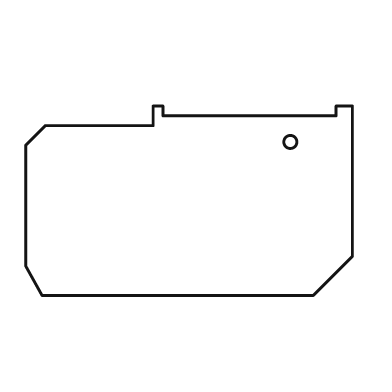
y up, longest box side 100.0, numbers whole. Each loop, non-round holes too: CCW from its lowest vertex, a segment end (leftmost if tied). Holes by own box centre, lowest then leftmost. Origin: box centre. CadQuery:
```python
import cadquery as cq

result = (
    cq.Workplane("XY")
    .moveTo(-45.0, -29.0)
    .lineTo(38.0, -29.0)
    .lineTo(50.0, -17.0)
    .lineTo(50.0, 29.0)
    .lineTo(45.0, 29.0)
    .lineTo(45.0, 26.0)
    .lineTo(-8.0, 26.0)
    .lineTo(-8.0, 29.0)
    .lineTo(-11.0, 29.0)
    .lineTo(-11.0, 23.0)
    .lineTo(-44.0, 23.0)
    .lineTo(-50.0, 17.0)
    .lineTo(-50.0, -20.0)
    .close()
    .moveTo(31.0, 18.0)
    .circle(2.0)
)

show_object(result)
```